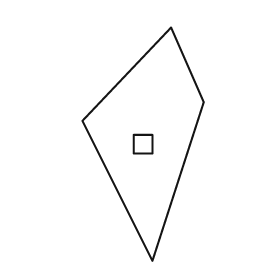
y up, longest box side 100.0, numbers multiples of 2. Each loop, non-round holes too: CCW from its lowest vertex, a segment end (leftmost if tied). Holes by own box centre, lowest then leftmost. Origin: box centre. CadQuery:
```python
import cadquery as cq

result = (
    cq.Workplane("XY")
    .moveTo(4.0, -50.0)
    .lineTo(26.0, 18.0)
    .lineTo(12.0, 50.0)
    .lineTo(-26.0, 10.0)
    .close()
    .moveTo(-4.0, -4.0)
    .lineTo(4.0, -4.0)
    .lineTo(4.0, 4.0)
    .lineTo(-4.0, 4.0)
    .close()
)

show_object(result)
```